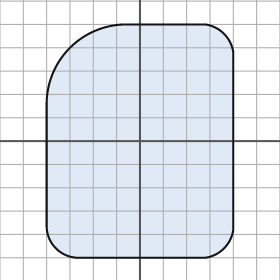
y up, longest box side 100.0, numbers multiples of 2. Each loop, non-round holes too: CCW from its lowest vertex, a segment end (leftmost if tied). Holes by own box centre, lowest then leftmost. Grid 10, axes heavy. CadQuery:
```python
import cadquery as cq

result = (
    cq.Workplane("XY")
    .moveTo(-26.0, -50.0)
    .lineTo(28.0, -50.0)
    .threePointArc((36.0, -46.0), (40.0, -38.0))
    .lineTo(40.0, 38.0)
    .threePointArc((36.0, 46.0), (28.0, 50.0))
    .lineTo(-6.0, 50.0)
    .threePointArc((-30.0, 40.0), (-40.0, 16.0))
    .lineTo(-40.0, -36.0)
    .threePointArc((-36.0, -46.0), (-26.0, -50.0))
    .close()
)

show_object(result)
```